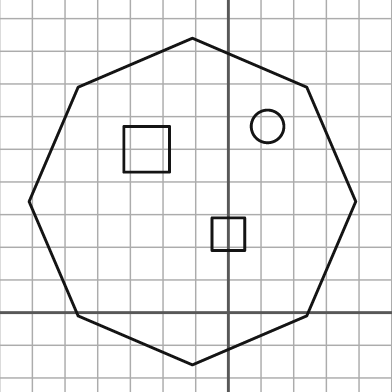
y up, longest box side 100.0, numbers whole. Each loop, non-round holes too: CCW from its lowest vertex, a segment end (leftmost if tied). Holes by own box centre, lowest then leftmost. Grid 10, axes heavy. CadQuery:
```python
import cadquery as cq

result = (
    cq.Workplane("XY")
    .moveTo(-11.0, -16.0)
    .lineTo(24.0, -1.0)
    .lineTo(39.0, 34.0)
    .lineTo(24.0, 69.0)
    .lineTo(-11.0, 84.0)
    .lineTo(-46.0, 69.0)
    .lineTo(-61.0, 34.0)
    .lineTo(-46.0, -1.0)
    .close()
    .moveTo(-5.0, 19.0)
    .lineTo(5.0, 19.0)
    .lineTo(5.0, 29.0)
    .lineTo(-5.0, 29.0)
    .close()
    .moveTo(-32.0, 43.0)
    .lineTo(-18.0, 43.0)
    .lineTo(-18.0, 57.0)
    .lineTo(-32.0, 57.0)
    .close()
    .moveTo(12.0, 57.0)
    .circle(5.0)
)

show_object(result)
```